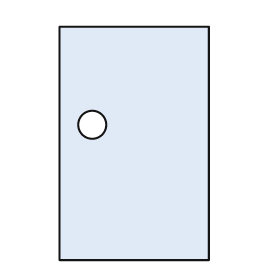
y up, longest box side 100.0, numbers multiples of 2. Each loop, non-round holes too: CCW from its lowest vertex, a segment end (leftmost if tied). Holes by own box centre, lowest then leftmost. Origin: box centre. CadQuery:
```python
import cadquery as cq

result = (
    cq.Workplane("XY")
    .moveTo(-32.0, -50.0)
    .lineTo(32.0, -50.0)
    .lineTo(32.0, 50.0)
    .lineTo(-32.0, 50.0)
    .close()
    .moveTo(-18.0, 8.0)
    .circle(6.0)
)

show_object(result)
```